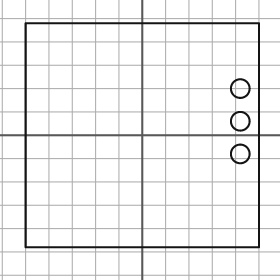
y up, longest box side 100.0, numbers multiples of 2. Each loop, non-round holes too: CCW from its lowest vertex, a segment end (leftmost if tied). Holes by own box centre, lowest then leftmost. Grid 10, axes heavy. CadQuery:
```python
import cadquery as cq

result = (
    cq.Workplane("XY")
    .moveTo(-50.0, -48.0)
    .lineTo(50.0, -48.0)
    .lineTo(50.0, 48.0)
    .lineTo(-50.0, 48.0)
    .close()
    .moveTo(42.0, -8.0)
    .circle(4.0)
    .moveTo(42.0, 6.0)
    .circle(4.0)
    .moveTo(42.0, 20.0)
    .circle(4.0)
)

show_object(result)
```